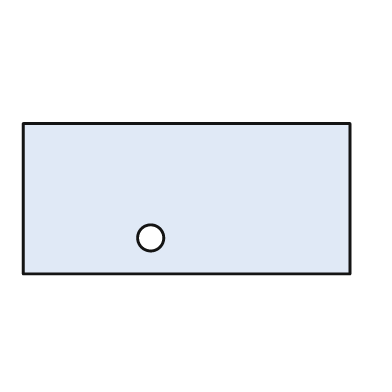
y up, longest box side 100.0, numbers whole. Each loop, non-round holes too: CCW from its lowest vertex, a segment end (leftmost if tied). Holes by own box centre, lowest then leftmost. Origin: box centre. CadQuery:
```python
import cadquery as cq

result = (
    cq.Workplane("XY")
    .moveTo(-50.0, -23.0)
    .lineTo(50.0, -23.0)
    .lineTo(50.0, 23.0)
    .lineTo(-50.0, 23.0)
    .close()
    .moveTo(-11.0, -12.0)
    .circle(4.0)
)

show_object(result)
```